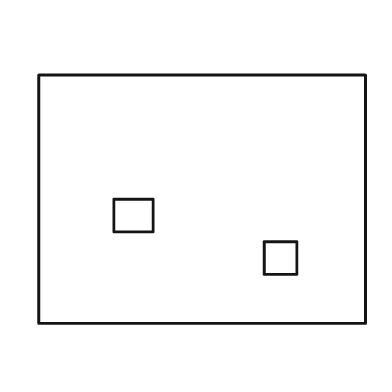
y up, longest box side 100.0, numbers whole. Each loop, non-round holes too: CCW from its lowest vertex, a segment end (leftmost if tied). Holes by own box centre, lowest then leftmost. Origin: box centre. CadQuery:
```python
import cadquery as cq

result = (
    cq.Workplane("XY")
    .moveTo(-50.0, -38.0)
    .lineTo(50.0, -38.0)
    .lineTo(50.0, 38.0)
    .lineTo(-50.0, 38.0)
    .close()
    .moveTo(19.0, -23.0)
    .lineTo(29.0, -23.0)
    .lineTo(29.0, -13.0)
    .lineTo(19.0, -13.0)
    .close()
    .moveTo(-27.0, -10.0)
    .lineTo(-15.0, -10.0)
    .lineTo(-15.0, 0.0)
    .lineTo(-27.0, 0.0)
    .close()
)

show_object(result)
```